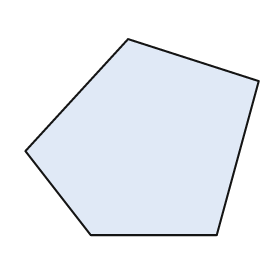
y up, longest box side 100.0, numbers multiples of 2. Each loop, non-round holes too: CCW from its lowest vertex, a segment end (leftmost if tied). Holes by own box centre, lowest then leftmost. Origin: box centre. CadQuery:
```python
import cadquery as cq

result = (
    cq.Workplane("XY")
    .moveTo(-22.0, -42.0)
    .lineTo(32.0, -42.0)
    .lineTo(50.0, 24.0)
    .lineTo(-6.0, 42.0)
    .lineTo(-50.0, -6.0)
    .close()
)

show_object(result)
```